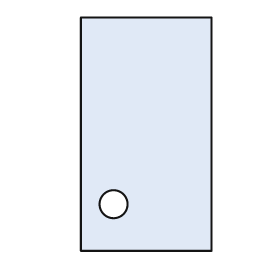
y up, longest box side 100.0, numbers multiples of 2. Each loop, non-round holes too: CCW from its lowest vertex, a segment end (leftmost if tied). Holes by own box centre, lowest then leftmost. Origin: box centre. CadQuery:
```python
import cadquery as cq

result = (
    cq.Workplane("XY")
    .moveTo(-28.0, -50.0)
    .lineTo(28.0, -50.0)
    .lineTo(28.0, 50.0)
    .lineTo(-28.0, 50.0)
    .close()
    .moveTo(-14.0, -30.0)
    .circle(6.0)
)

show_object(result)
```